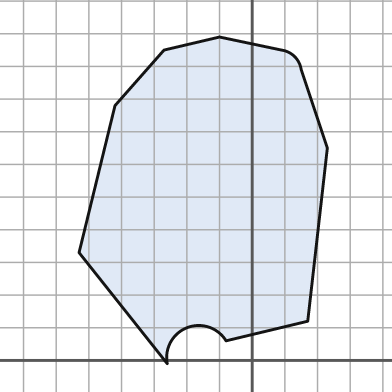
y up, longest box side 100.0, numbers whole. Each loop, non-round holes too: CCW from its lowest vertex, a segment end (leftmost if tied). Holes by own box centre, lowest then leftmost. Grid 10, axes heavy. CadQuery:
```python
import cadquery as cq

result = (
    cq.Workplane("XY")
    .moveTo(-26.0, -1.0)
    .threePointArc((-20.0, 10.0), (-8.0, 6.0))
    .lineTo(17.0, 12.0)
    .lineTo(23.0, 65.0)
    .lineTo(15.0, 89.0)
    .threePointArc((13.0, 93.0), (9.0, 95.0))
    .lineTo(-10.0, 99.0)
    .lineTo(-27.0, 95.0)
    .lineTo(-42.0, 78.0)
    .lineTo(-53.0, 33.0)
    .close()
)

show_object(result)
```